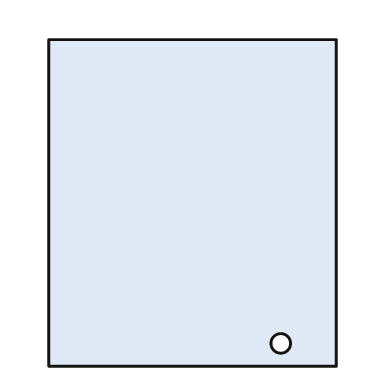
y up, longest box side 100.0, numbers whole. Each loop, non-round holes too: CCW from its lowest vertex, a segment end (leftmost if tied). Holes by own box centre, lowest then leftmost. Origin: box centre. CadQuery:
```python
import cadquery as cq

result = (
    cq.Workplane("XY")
    .moveTo(-44.0, -50.0)
    .lineTo(44.0, -50.0)
    .lineTo(44.0, 50.0)
    .lineTo(-44.0, 50.0)
    .close()
    .moveTo(27.0, -43.0)
    .circle(3.0)
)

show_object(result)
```